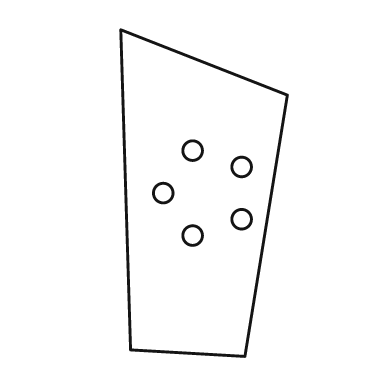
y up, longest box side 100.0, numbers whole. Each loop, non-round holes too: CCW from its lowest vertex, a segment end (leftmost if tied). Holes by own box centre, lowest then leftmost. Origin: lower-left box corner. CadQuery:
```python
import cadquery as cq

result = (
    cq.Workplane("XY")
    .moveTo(38.0, 0.0)
    .lineTo(51.0, 80.0)
    .lineTo(0.0, 100.0)
    .lineTo(3.0, 2.0)
    .close()
    .moveTo(22.0, 37.0)
    .circle(3.0)
    .moveTo(37.0, 42.0)
    .circle(3.0)
    .moveTo(13.0, 50.0)
    .circle(3.0)
    .moveTo(37.0, 58.0)
    .circle(3.0)
    .moveTo(22.0, 63.0)
    .circle(3.0)
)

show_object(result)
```